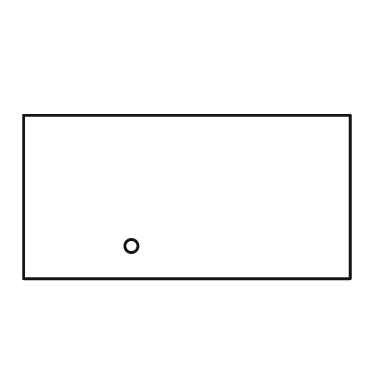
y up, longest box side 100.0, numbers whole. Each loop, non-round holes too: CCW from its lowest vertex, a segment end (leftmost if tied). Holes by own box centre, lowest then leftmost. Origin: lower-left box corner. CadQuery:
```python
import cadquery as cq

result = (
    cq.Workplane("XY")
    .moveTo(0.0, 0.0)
    .lineTo(100.0, 0.0)
    .lineTo(100.0, 50.0)
    .lineTo(0.0, 50.0)
    .close()
    .moveTo(33.0, 10.0)
    .circle(2.0)
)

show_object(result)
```